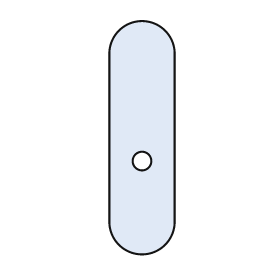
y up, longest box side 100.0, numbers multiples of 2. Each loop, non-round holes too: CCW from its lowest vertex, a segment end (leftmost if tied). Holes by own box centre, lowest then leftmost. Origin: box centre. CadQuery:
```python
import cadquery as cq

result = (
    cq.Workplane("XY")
    .moveTo(-14.0, -36.0)
    .threePointArc((0.0, -50.0), (14.0, -36.0))
    .lineTo(14.0, 36.0)
    .threePointArc((0.0, 50.0), (-14.0, 36.0))
    .close()
    .moveTo(0.0, -10.0)
    .circle(4.0)
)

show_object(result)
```